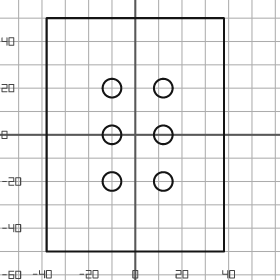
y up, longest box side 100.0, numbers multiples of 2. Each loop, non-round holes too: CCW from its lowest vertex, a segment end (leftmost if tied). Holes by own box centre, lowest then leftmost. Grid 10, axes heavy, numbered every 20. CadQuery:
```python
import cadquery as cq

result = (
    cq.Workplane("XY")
    .moveTo(-38.0, -50.0)
    .lineTo(38.0, -50.0)
    .lineTo(38.0, 50.0)
    .lineTo(-38.0, 50.0)
    .close()
    .moveTo(-10.0, -20.0)
    .circle(4.0)
    .moveTo(12.0, -20.0)
    .circle(4.0)
    .moveTo(-10.0, 0.0)
    .circle(4.0)
    .moveTo(12.0, 0.0)
    .circle(4.0)
    .moveTo(-10.0, 20.0)
    .circle(4.0)
    .moveTo(12.0, 20.0)
    .circle(4.0)
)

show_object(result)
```